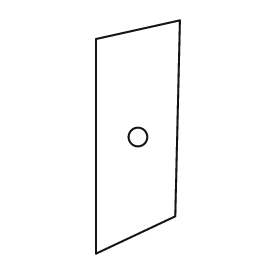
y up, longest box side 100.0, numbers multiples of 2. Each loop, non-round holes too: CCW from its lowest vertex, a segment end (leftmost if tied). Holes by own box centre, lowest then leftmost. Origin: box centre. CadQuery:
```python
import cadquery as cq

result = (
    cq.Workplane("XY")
    .moveTo(-18.0, -50.0)
    .lineTo(16.0, -34.0)
    .lineTo(18.0, 50.0)
    .lineTo(-18.0, 42.0)
    .close()
    .moveTo(0.0, 0.0)
    .circle(4.0)
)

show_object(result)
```